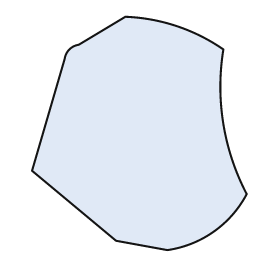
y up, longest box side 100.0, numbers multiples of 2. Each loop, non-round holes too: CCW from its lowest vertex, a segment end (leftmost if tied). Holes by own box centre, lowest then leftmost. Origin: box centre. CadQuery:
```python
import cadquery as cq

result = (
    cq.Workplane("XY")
    .moveTo(12.0, -50.0)
    .threePointArc((32.0, -42.0), (46.0, -26.0))
    .threePointArc((36.0, 4.0), (36.0, 36.0))
    .threePointArc((16.0, 46.0), (-6.0, 50.0))
    .lineTo(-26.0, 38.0)
    .threePointArc((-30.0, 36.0), (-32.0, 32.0))
    .lineTo(-46.0, -16.0)
    .lineTo(-10.0, -46.0)
    .close()
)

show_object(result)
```